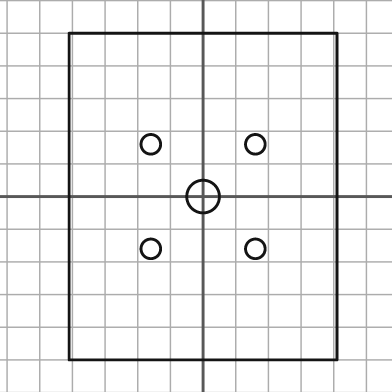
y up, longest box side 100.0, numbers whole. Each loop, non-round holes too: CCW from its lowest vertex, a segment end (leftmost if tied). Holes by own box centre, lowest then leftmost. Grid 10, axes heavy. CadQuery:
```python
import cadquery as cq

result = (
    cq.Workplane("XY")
    .moveTo(-41.0, -50.0)
    .lineTo(41.0, -50.0)
    .lineTo(41.0, 50.0)
    .lineTo(-41.0, 50.0)
    .close()
    .moveTo(-16.0, -16.0)
    .circle(3.0)
    .moveTo(16.0, -16.0)
    .circle(3.0)
    .moveTo(0.0, 0.0)
    .circle(5.0)
    .moveTo(-16.0, 16.0)
    .circle(3.0)
    .moveTo(16.0, 16.0)
    .circle(3.0)
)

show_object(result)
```